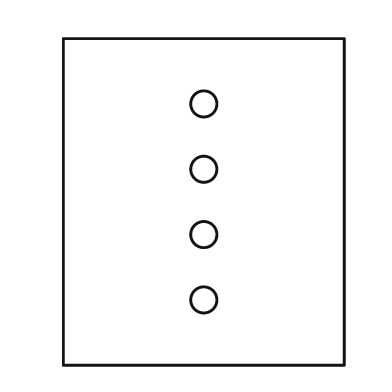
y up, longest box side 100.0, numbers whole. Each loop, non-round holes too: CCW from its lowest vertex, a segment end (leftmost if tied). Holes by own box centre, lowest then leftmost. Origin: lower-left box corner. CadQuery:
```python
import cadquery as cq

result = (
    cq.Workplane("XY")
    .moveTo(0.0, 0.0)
    .lineTo(86.0, 0.0)
    .lineTo(86.0, 100.0)
    .lineTo(0.0, 100.0)
    .close()
    .moveTo(43.0, 20.0)
    .circle(4.0)
    .moveTo(43.0, 40.0)
    .circle(4.0)
    .moveTo(43.0, 60.0)
    .circle(4.0)
    .moveTo(43.0, 80.0)
    .circle(4.0)
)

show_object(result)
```